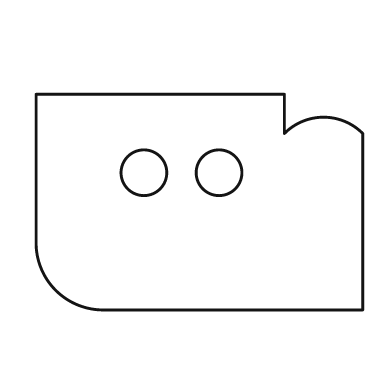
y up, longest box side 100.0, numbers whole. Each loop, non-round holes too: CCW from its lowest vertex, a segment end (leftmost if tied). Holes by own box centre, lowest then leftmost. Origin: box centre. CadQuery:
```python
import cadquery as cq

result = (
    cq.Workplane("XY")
    .moveTo(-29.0, -33.0)
    .lineTo(50.0, -33.0)
    .lineTo(50.0, 21.0)
    .threePointArc((38.0, 26.0), (26.0, 21.0))
    .lineTo(26.0, 33.0)
    .lineTo(-50.0, 33.0)
    .lineTo(-50.0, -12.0)
    .threePointArc((-44.0, -27.0), (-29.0, -33.0))
    .close()
    .moveTo(-17.0, 9.0)
    .circle(7.0)
    .moveTo(6.0, 9.0)
    .circle(7.0)
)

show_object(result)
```